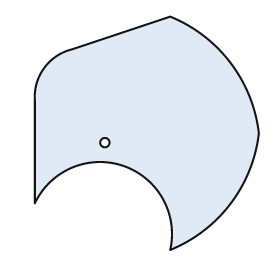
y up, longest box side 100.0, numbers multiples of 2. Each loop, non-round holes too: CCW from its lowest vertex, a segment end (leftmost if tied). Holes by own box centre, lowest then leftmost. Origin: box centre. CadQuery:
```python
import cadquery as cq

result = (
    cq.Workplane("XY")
    .moveTo(10.0, -50.0)
    .threePointArc((36.0, -30.0), (48.0, 0.0))
    .threePointArc((36.0, 30.0), (10.0, 50.0))
    .lineTo(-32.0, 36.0)
    .threePointArc((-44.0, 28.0), (-48.0, 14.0))
    .lineTo(-48.0, -30.0)
    .threePointArc((-10.0, -14.0), (10.0, -50.0))
    .close()
    .moveTo(-18.0, -4.0)
    .circle(2.0)
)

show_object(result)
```